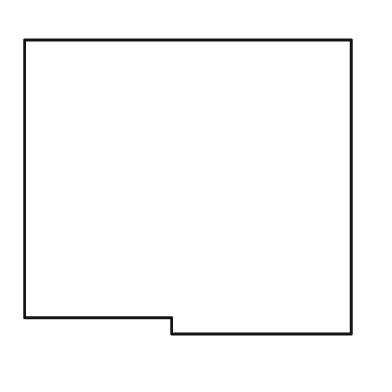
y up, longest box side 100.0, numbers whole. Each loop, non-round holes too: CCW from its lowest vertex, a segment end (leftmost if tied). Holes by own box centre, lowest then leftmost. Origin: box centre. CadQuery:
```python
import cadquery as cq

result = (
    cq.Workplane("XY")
    .moveTo(-5.0, -45.0)
    .lineTo(50.0, -45.0)
    .lineTo(50.0, 45.0)
    .lineTo(-50.0, 45.0)
    .lineTo(-50.0, -40.0)
    .lineTo(-5.0, -40.0)
    .close()
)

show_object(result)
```